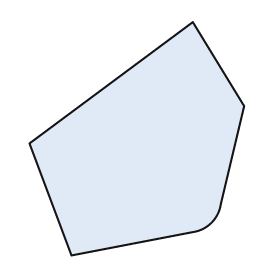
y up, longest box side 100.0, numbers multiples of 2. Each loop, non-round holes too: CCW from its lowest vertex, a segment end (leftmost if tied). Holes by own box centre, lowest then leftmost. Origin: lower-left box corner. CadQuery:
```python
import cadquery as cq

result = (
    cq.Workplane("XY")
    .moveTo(18.0, 0.0)
    .lineTo(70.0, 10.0)
    .threePointArc((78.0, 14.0), (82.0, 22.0))
    .lineTo(92.0, 64.0)
    .lineTo(70.0, 100.0)
    .lineTo(0.0, 48.0)
    .close()
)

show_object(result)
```